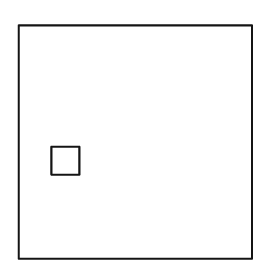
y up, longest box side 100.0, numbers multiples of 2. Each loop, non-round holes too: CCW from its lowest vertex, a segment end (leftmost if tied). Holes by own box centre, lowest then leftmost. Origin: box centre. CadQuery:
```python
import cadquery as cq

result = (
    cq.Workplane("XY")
    .moveTo(-50.0, -50.0)
    .lineTo(50.0, -50.0)
    .lineTo(50.0, 50.0)
    .lineTo(-50.0, 50.0)
    .close()
    .moveTo(-36.0, -14.0)
    .lineTo(-24.0, -14.0)
    .lineTo(-24.0, -2.0)
    .lineTo(-36.0, -2.0)
    .close()
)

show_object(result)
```